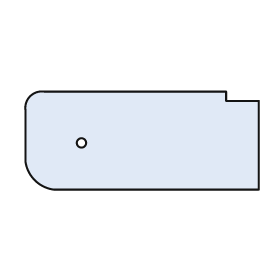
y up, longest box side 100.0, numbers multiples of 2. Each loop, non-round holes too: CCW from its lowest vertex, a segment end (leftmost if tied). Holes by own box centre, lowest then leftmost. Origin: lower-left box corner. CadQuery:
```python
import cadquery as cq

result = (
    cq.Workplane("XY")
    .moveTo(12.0, 0.0)
    .lineTo(100.0, 0.0)
    .lineTo(100.0, 38.0)
    .lineTo(86.0, 38.0)
    .lineTo(86.0, 42.0)
    .lineTo(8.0, 42.0)
    .threePointArc((2.0, 40.0), (0.0, 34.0))
    .lineTo(0.0, 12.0)
    .threePointArc((4.0, 4.0), (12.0, 0.0))
    .close()
    .moveTo(24.0, 20.0)
    .circle(2.0)
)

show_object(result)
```